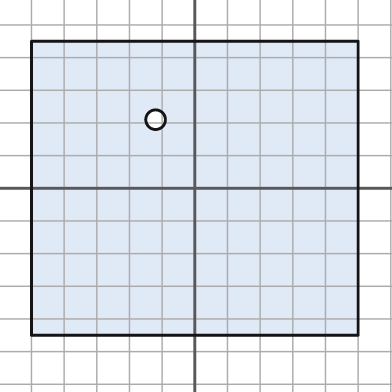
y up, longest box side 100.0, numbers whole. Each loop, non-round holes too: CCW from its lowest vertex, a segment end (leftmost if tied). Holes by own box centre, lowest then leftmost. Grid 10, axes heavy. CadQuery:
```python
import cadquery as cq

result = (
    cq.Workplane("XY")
    .moveTo(-50.0, -45.0)
    .lineTo(50.0, -45.0)
    .lineTo(50.0, 45.0)
    .lineTo(-50.0, 45.0)
    .close()
    .moveTo(-12.0, 21.0)
    .circle(3.0)
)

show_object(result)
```